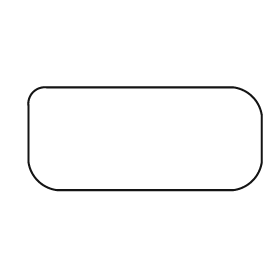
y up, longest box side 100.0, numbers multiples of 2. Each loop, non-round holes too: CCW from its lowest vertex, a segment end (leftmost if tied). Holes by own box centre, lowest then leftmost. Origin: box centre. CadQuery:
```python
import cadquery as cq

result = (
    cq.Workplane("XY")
    .moveTo(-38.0, -22.0)
    .lineTo(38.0, -22.0)
    .threePointArc((46.0, -18.0), (50.0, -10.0))
    .lineTo(50.0, 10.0)
    .threePointArc((46.0, 18.0), (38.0, 22.0))
    .lineTo(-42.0, 22.0)
    .threePointArc((-48.0, 20.0), (-50.0, 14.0))
    .lineTo(-50.0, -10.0)
    .threePointArc((-46.0, -18.0), (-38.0, -22.0))
    .close()
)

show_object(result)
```